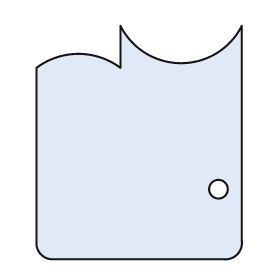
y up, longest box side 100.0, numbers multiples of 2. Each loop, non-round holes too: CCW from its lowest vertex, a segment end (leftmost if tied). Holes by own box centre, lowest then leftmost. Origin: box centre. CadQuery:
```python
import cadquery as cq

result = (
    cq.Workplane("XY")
    .moveTo(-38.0, -50.0)
    .lineTo(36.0, -50.0)
    .threePointArc((42.0, -48.0), (44.0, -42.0))
    .lineTo(44.0, 50.0)
    .threePointArc((18.0, 34.0), (-8.0, 50.0))
    .lineTo(-8.0, 32.0)
    .threePointArc((-26.0, 38.0), (-44.0, 32.0))
    .lineTo(-44.0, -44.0)
    .threePointArc((-42.0, -48.0), (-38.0, -50.0))
    .close()
    .moveTo(34.0, -20.0)
    .circle(4.0)
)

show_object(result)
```